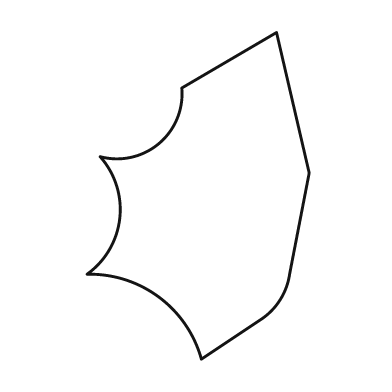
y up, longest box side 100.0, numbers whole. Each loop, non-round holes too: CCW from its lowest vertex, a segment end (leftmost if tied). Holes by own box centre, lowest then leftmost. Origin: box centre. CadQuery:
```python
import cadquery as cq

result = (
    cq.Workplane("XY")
    .moveTo(1.0, -50.0)
    .lineTo(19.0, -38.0)
    .threePointArc((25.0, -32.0), (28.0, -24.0))
    .lineTo(34.0, 7.0)
    .lineTo(24.0, 50.0)
    .lineTo(-5.0, 33.0)
    .threePointArc((-12.0, 16.0), (-30.0, 12.0))
    .threePointArc((-24.0, -7.0), (-34.0, -24.0))
    .threePointArc((-12.0, -31.0), (1.0, -50.0))
    .close()
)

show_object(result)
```